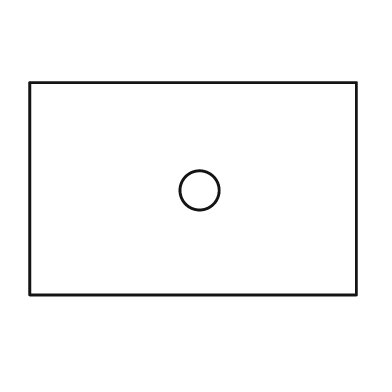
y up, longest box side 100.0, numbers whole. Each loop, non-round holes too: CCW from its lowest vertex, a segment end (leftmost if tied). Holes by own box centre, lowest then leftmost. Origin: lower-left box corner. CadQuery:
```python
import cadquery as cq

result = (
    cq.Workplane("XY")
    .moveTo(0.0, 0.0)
    .lineTo(100.0, 0.0)
    .lineTo(100.0, 65.0)
    .lineTo(0.0, 65.0)
    .close()
    .moveTo(52.0, 32.0)
    .circle(6.0)
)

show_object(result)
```